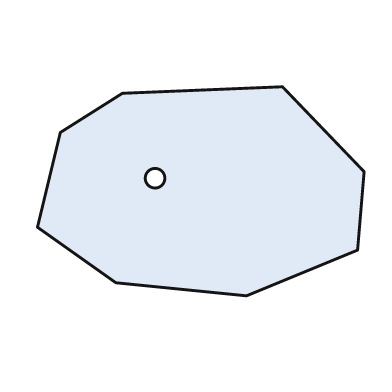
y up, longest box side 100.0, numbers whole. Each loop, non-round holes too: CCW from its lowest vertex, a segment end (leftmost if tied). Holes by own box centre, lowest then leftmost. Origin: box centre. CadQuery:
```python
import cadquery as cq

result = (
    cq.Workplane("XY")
    .moveTo(14.0, -32.0)
    .lineTo(48.0, -18.0)
    .lineTo(50.0, 6.0)
    .lineTo(25.0, 32.0)
    .lineTo(-24.0, 30.0)
    .lineTo(-43.0, 18.0)
    .lineTo(-50.0, -11.0)
    .lineTo(-26.0, -28.0)
    .close()
    .moveTo(-14.0, 4.0)
    .circle(3.0)
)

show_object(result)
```